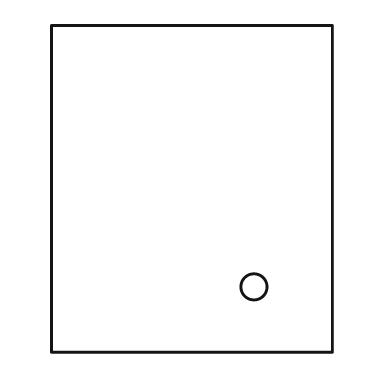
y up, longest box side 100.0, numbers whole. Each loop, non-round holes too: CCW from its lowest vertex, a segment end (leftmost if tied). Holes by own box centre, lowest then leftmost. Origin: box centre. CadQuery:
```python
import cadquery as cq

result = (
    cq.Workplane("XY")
    .moveTo(-43.0, -50.0)
    .lineTo(43.0, -50.0)
    .lineTo(43.0, 50.0)
    .lineTo(-43.0, 50.0)
    .close()
    .moveTo(19.0, -30.0)
    .circle(4.0)
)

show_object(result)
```